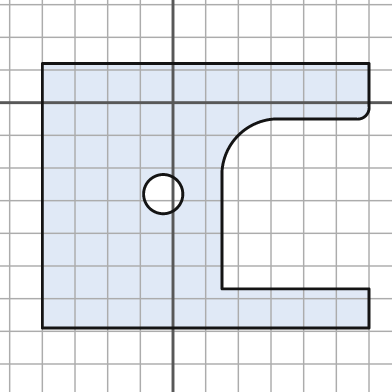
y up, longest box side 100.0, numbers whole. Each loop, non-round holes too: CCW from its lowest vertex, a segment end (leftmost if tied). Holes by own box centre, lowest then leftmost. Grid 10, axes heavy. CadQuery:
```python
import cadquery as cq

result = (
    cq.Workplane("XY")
    .moveTo(-40.0, -69.0)
    .lineTo(60.0, -69.0)
    .lineTo(60.0, -57.0)
    .lineTo(15.0, -57.0)
    .lineTo(15.0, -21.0)
    .threePointArc((20.0, -10.0), (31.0, -5.0))
    .lineTo(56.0, -5.0)
    .threePointArc((59.0, -4.0), (60.0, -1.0))
    .lineTo(60.0, 12.0)
    .lineTo(-40.0, 12.0)
    .close()
    .moveTo(-3.0, -28.0)
    .circle(6.0)
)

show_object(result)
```